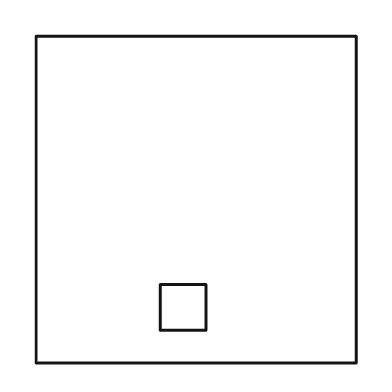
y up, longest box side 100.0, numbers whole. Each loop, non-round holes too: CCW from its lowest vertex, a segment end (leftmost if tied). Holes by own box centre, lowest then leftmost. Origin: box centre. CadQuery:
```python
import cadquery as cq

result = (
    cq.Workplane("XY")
    .moveTo(-49.0, -50.0)
    .lineTo(49.0, -50.0)
    .lineTo(49.0, 50.0)
    .lineTo(-49.0, 50.0)
    .close()
    .moveTo(-11.0, -40.0)
    .lineTo(3.0, -40.0)
    .lineTo(3.0, -26.0)
    .lineTo(-11.0, -26.0)
    .close()
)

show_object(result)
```